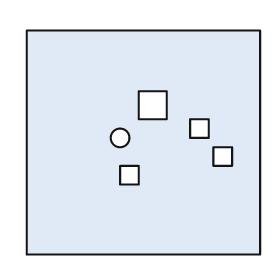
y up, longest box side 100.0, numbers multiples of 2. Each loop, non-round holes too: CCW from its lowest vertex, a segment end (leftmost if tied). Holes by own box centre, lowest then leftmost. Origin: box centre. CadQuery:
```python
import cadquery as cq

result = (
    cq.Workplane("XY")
    .moveTo(-50.0, -48.0)
    .lineTo(50.0, -48.0)
    .lineTo(50.0, 48.0)
    .lineTo(-50.0, 48.0)
    .close()
    .moveTo(-10.0, -18.0)
    .lineTo(-2.0, -18.0)
    .lineTo(-2.0, -10.0)
    .lineTo(-10.0, -10.0)
    .close()
    .moveTo(30.0, -10.0)
    .lineTo(38.0, -10.0)
    .lineTo(38.0, -2.0)
    .lineTo(30.0, -2.0)
    .close()
    .moveTo(-10.0, 2.0)
    .circle(4.0)
    .moveTo(20.0, 2.0)
    .lineTo(28.0, 2.0)
    .lineTo(28.0, 10.0)
    .lineTo(20.0, 10.0)
    .close()
    .moveTo(-2.0, 10.0)
    .lineTo(10.0, 10.0)
    .lineTo(10.0, 22.0)
    .lineTo(-2.0, 22.0)
    .close()
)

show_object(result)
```